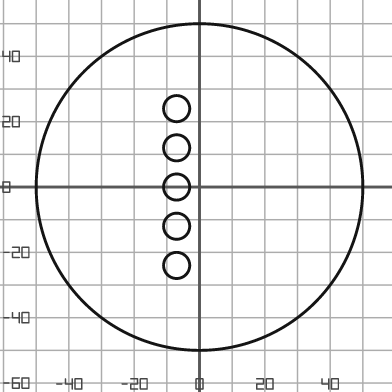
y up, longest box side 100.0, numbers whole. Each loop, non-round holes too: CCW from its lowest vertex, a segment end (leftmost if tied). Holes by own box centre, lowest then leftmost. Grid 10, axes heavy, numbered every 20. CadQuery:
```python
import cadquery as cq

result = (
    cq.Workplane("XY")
    .moveTo(0.0, 0.0)
    .circle(50.0)
    .moveTo(-7.0, -24.0)
    .circle(4.0)
    .moveTo(-7.0, -12.0)
    .circle(4.0)
    .moveTo(-7.0, 0.0)
    .circle(4.0)
    .moveTo(-7.0, 12.0)
    .circle(4.0)
    .moveTo(-7.0, 24.0)
    .circle(4.0)
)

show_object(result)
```